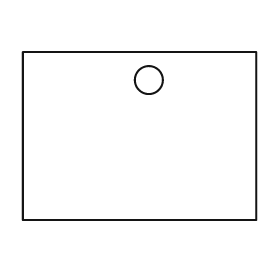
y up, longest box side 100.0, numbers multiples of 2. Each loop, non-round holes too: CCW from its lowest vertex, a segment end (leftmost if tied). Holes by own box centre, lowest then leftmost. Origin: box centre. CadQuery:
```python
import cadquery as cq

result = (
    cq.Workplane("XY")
    .moveTo(-50.0, -36.0)
    .lineTo(50.0, -36.0)
    .lineTo(50.0, 36.0)
    .lineTo(-50.0, 36.0)
    .close()
    .moveTo(4.0, 24.0)
    .circle(6.0)
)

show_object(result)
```